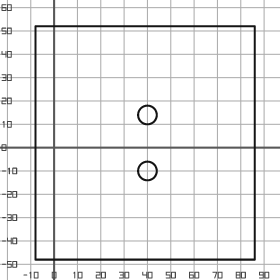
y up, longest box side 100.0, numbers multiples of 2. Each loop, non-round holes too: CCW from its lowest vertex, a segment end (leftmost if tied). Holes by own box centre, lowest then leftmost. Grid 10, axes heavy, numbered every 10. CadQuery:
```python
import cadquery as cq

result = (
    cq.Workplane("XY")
    .moveTo(-8.0, -48.0)
    .lineTo(86.0, -48.0)
    .lineTo(86.0, 52.0)
    .lineTo(-8.0, 52.0)
    .close()
    .moveTo(40.0, -10.0)
    .circle(4.0)
    .moveTo(40.0, 14.0)
    .circle(4.0)
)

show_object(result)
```